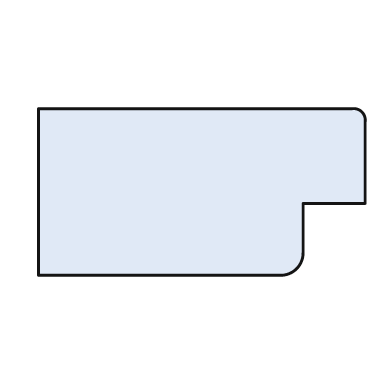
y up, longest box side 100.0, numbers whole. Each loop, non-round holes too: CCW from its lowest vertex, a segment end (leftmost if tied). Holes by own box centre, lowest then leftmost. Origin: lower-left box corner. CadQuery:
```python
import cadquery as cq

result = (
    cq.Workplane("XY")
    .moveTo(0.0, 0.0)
    .lineTo(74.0, 0.0)
    .threePointArc((79.0, 2.0), (81.0, 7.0))
    .lineTo(81.0, 22.0)
    .lineTo(100.0, 22.0)
    .lineTo(100.0, 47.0)
    .threePointArc((99.0, 50.0), (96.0, 51.0))
    .lineTo(0.0, 51.0)
    .close()
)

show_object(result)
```